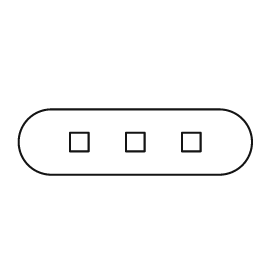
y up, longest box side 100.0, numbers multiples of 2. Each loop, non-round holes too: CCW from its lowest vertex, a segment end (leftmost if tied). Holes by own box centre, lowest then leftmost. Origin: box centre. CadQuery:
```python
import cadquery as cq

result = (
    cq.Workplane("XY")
    .moveTo(-36.0, -14.0)
    .lineTo(36.0, -14.0)
    .threePointArc((50.0, 0.0), (36.0, 14.0))
    .lineTo(-36.0, 14.0)
    .threePointArc((-50.0, 0.0), (-36.0, -14.0))
    .close()
    .moveTo(-28.0, -4.0)
    .lineTo(-20.0, -4.0)
    .lineTo(-20.0, 4.0)
    .lineTo(-28.0, 4.0)
    .close()
    .moveTo(-4.0, -4.0)
    .lineTo(4.0, -4.0)
    .lineTo(4.0, 4.0)
    .lineTo(-4.0, 4.0)
    .close()
    .moveTo(20.0, -4.0)
    .lineTo(28.0, -4.0)
    .lineTo(28.0, 4.0)
    .lineTo(20.0, 4.0)
    .close()
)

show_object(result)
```